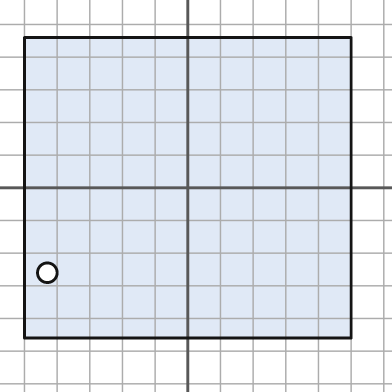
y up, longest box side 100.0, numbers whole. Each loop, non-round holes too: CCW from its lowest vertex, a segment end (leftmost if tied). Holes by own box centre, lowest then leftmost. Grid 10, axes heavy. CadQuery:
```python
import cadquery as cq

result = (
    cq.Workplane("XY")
    .moveTo(-50.0, -46.0)
    .lineTo(50.0, -46.0)
    .lineTo(50.0, 46.0)
    .lineTo(-50.0, 46.0)
    .close()
    .moveTo(-43.0, -26.0)
    .circle(3.0)
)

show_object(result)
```